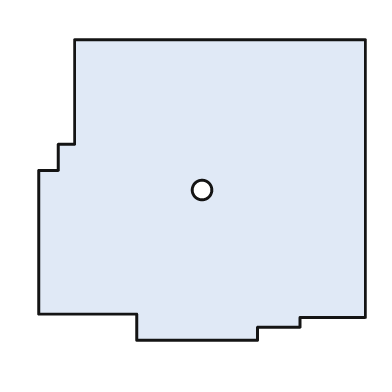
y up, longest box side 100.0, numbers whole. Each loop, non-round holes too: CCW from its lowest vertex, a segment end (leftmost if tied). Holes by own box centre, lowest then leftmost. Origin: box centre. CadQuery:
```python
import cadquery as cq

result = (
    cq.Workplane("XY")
    .moveTo(-20.0, -46.0)
    .lineTo(17.0, -46.0)
    .lineTo(17.0, -42.0)
    .lineTo(30.0, -42.0)
    .lineTo(30.0, -39.0)
    .lineTo(50.0, -39.0)
    .lineTo(50.0, 46.0)
    .lineTo(-39.0, 46.0)
    .lineTo(-39.0, 14.0)
    .lineTo(-44.0, 14.0)
    .lineTo(-44.0, 6.0)
    .lineTo(-50.0, 6.0)
    .lineTo(-50.0, -38.0)
    .lineTo(-20.0, -38.0)
    .close()
    .moveTo(0.0, 0.0)
    .circle(3.0)
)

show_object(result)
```